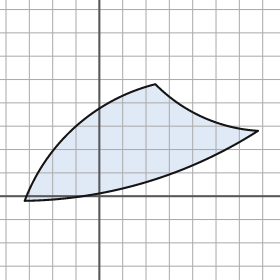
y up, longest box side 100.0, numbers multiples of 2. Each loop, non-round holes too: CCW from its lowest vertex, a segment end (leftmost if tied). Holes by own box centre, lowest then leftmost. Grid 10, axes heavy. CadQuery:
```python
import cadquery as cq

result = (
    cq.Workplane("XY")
    .moveTo(-32.0, -2.0)
    .threePointArc((20.0, 6.0), (68.0, 28.0))
    .threePointArc((44.0, 34.0), (24.0, 48.0))
    .threePointArc((-10.0, 30.0), (-32.0, -2.0))
    .close()
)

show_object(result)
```